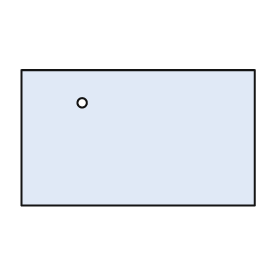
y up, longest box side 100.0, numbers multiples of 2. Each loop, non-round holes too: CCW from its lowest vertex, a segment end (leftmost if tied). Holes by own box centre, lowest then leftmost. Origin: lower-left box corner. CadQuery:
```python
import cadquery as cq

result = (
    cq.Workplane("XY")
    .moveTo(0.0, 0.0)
    .lineTo(100.0, 0.0)
    .lineTo(100.0, 58.0)
    .lineTo(0.0, 58.0)
    .close()
    .moveTo(26.0, 44.0)
    .circle(2.0)
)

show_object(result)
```